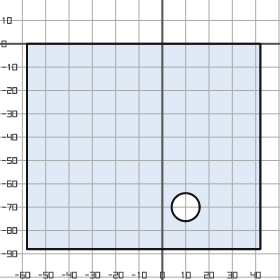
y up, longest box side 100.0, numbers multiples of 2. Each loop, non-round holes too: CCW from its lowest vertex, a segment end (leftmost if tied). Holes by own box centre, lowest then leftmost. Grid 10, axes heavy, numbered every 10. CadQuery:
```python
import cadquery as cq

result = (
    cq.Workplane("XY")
    .moveTo(-58.0, -88.0)
    .lineTo(42.0, -88.0)
    .lineTo(42.0, 0.0)
    .lineTo(-58.0, 0.0)
    .close()
    .moveTo(10.0, -70.0)
    .circle(6.0)
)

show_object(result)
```